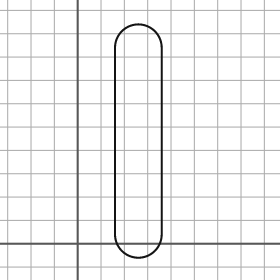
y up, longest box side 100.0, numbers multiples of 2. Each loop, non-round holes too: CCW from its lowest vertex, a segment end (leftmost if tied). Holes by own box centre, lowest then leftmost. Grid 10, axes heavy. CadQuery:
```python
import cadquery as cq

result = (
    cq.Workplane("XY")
    .moveTo(16.0, 4.0)
    .threePointArc((26.0, -6.0), (36.0, 4.0))
    .lineTo(36.0, 84.0)
    .threePointArc((26.0, 94.0), (16.0, 84.0))
    .close()
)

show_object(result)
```